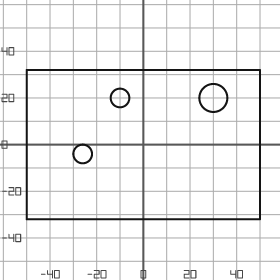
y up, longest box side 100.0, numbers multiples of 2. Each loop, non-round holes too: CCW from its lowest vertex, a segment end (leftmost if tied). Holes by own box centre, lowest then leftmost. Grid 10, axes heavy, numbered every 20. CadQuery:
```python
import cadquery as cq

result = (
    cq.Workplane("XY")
    .moveTo(-50.0, -32.0)
    .lineTo(50.0, -32.0)
    .lineTo(50.0, 32.0)
    .lineTo(-50.0, 32.0)
    .close()
    .moveTo(-26.0, -4.0)
    .circle(4.0)
    .moveTo(-10.0, 20.0)
    .circle(4.0)
    .moveTo(30.0, 20.0)
    .circle(6.0)
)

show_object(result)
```